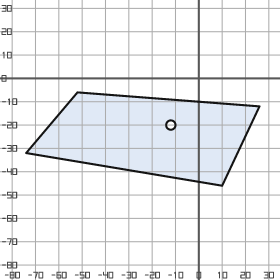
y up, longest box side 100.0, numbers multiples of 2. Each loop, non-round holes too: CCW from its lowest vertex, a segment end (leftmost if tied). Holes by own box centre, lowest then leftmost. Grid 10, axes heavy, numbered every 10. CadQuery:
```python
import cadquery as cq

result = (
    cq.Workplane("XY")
    .moveTo(10.0, -46.0)
    .lineTo(26.0, -12.0)
    .lineTo(-52.0, -6.0)
    .lineTo(-74.0, -32.0)
    .close()
    .moveTo(-12.0, -20.0)
    .circle(2.0)
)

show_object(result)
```